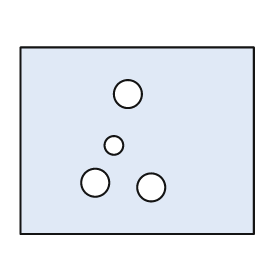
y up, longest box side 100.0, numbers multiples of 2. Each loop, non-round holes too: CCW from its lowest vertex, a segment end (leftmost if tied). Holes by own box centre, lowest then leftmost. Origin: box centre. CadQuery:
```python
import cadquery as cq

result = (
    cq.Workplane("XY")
    .moveTo(-50.0, -40.0)
    .lineTo(50.0, -40.0)
    .lineTo(50.0, 40.0)
    .lineTo(-50.0, 40.0)
    .close()
    .moveTo(6.0, -20.0)
    .circle(6.0)
    .moveTo(-18.0, -18.0)
    .circle(6.0)
    .moveTo(-10.0, -2.0)
    .circle(4.0)
    .moveTo(-4.0, 20.0)
    .circle(6.0)
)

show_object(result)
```